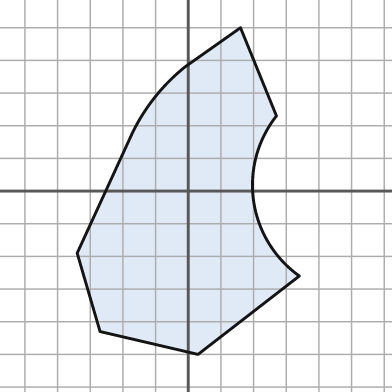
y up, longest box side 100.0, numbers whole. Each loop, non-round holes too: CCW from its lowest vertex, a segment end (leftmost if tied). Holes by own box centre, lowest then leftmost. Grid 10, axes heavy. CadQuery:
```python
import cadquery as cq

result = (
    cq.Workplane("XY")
    .moveTo(3.0, -50.0)
    .lineTo(34.0, -26.0)
    .threePointArc((20.0, -3.0), (27.0, 23.0))
    .lineTo(16.0, 50.0)
    .lineTo(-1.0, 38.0)
    .threePointArc((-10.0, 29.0), (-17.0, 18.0))
    .lineTo(-34.0, -19.0)
    .lineTo(-27.0, -43.0)
    .close()
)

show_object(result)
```